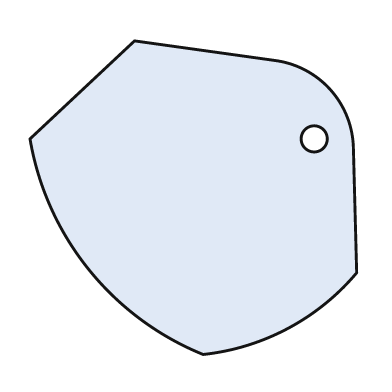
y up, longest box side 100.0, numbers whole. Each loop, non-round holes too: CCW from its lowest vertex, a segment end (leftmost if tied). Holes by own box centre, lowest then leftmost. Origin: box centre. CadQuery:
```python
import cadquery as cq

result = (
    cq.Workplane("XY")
    .moveTo(3.0, -48.0)
    .threePointArc((29.0, -40.0), (50.0, -23.0))
    .lineTo(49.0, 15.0)
    .threePointArc((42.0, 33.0), (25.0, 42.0))
    .lineTo(-18.0, 48.0)
    .lineTo(-50.0, 18.0)
    .threePointArc((-32.0, -22.0), (3.0, -48.0))
    .close()
    .moveTo(37.0, 18.0)
    .circle(4.0)
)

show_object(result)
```